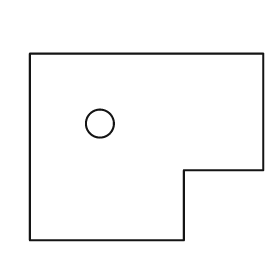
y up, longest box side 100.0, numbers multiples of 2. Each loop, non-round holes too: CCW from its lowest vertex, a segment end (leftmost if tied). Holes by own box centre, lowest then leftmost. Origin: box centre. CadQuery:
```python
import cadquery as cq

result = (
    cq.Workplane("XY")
    .moveTo(-50.0, -40.0)
    .lineTo(16.0, -40.0)
    .lineTo(16.0, -10.0)
    .lineTo(50.0, -10.0)
    .lineTo(50.0, 40.0)
    .lineTo(-50.0, 40.0)
    .close()
    .moveTo(-20.0, 10.0)
    .circle(6.0)
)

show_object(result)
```